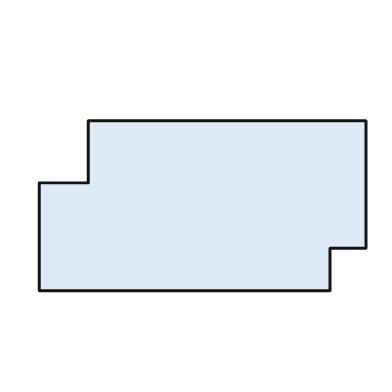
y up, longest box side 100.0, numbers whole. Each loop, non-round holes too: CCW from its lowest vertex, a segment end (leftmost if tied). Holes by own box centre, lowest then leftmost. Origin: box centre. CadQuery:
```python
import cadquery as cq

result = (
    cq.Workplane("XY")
    .moveTo(-50.0, -26.0)
    .lineTo(39.0, -26.0)
    .lineTo(39.0, -13.0)
    .lineTo(50.0, -13.0)
    .lineTo(50.0, 26.0)
    .lineTo(-35.0, 26.0)
    .lineTo(-35.0, 7.0)
    .lineTo(-50.0, 7.0)
    .close()
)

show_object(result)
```